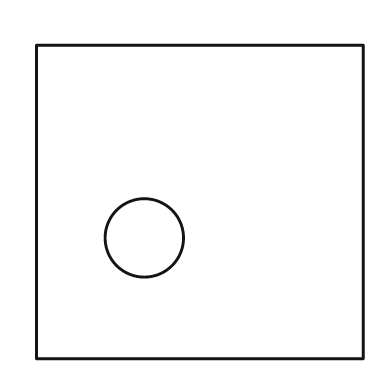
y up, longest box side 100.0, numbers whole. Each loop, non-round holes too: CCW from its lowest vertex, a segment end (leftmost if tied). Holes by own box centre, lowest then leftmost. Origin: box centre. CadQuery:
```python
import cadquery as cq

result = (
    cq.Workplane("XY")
    .moveTo(-50.0, -48.0)
    .lineTo(50.0, -48.0)
    .lineTo(50.0, 48.0)
    .lineTo(-50.0, 48.0)
    .close()
    .moveTo(-17.0, -11.0)
    .circle(12.0)
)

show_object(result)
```